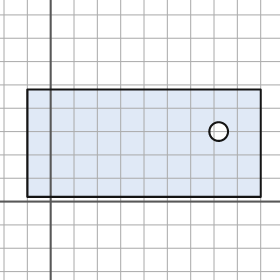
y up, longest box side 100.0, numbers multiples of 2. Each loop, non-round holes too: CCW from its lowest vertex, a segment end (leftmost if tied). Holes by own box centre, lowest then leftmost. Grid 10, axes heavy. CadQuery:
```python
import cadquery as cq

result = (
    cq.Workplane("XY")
    .moveTo(-10.0, 2.0)
    .lineTo(90.0, 2.0)
    .lineTo(90.0, 48.0)
    .lineTo(-10.0, 48.0)
    .close()
    .moveTo(72.0, 30.0)
    .circle(4.0)
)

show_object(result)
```